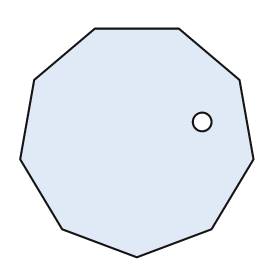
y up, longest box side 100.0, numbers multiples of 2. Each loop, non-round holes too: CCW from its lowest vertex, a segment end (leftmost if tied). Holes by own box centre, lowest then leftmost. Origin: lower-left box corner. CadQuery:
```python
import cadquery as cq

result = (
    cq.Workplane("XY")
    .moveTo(50.0, 0.0)
    .lineTo(82.0, 12.0)
    .lineTo(100.0, 42.0)
    .lineTo(94.0, 76.0)
    .lineTo(68.0, 98.0)
    .lineTo(32.0, 98.0)
    .lineTo(6.0, 76.0)
    .lineTo(0.0, 42.0)
    .lineTo(18.0, 12.0)
    .close()
    .moveTo(78.0, 58.0)
    .circle(4.0)
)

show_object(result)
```